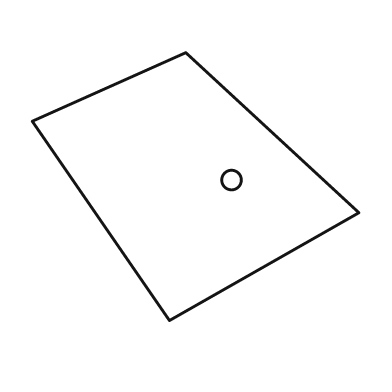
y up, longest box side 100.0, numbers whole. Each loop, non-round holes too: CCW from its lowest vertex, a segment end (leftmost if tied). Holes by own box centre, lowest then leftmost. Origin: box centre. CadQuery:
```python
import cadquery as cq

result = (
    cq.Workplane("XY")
    .moveTo(-8.0, -41.0)
    .lineTo(50.0, -8.0)
    .lineTo(-3.0, 41.0)
    .lineTo(-50.0, 20.0)
    .close()
    .moveTo(11.0, 2.0)
    .circle(3.0)
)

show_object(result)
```